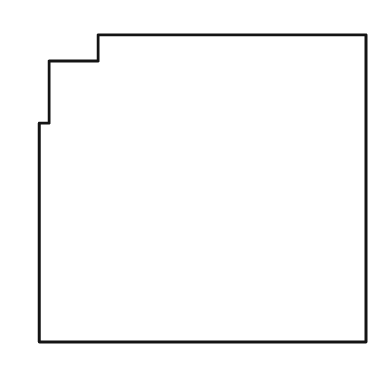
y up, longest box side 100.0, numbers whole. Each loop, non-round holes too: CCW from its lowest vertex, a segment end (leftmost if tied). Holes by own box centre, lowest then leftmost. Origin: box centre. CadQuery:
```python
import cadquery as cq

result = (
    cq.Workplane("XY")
    .moveTo(-50.0, -47.0)
    .lineTo(50.0, -47.0)
    .lineTo(50.0, 47.0)
    .lineTo(-32.0, 47.0)
    .lineTo(-32.0, 39.0)
    .lineTo(-47.0, 39.0)
    .lineTo(-47.0, 20.0)
    .lineTo(-50.0, 20.0)
    .close()
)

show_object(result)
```